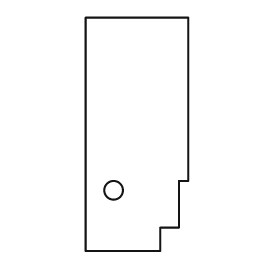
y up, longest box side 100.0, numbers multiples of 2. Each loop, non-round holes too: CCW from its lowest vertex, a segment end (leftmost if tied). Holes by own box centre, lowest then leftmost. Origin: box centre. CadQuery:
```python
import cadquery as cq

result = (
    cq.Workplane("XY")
    .moveTo(-22.0, -50.0)
    .lineTo(10.0, -50.0)
    .lineTo(10.0, -40.0)
    .lineTo(18.0, -40.0)
    .lineTo(18.0, -20.0)
    .lineTo(22.0, -20.0)
    .lineTo(22.0, 50.0)
    .lineTo(-22.0, 50.0)
    .close()
    .moveTo(-10.0, -24.0)
    .circle(4.0)
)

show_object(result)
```